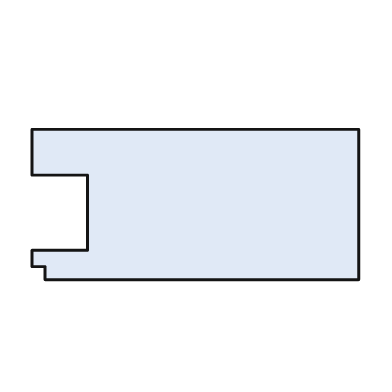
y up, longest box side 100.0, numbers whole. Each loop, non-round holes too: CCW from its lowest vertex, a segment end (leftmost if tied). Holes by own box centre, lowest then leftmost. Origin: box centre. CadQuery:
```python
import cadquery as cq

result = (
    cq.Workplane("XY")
    .moveTo(-46.0, -23.0)
    .lineTo(50.0, -23.0)
    .lineTo(50.0, 23.0)
    .lineTo(-50.0, 23.0)
    .lineTo(-50.0, 9.0)
    .lineTo(-33.0, 9.0)
    .lineTo(-33.0, -14.0)
    .lineTo(-50.0, -14.0)
    .lineTo(-50.0, -19.0)
    .lineTo(-46.0, -19.0)
    .close()
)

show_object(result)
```